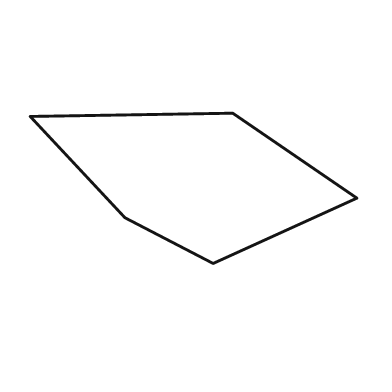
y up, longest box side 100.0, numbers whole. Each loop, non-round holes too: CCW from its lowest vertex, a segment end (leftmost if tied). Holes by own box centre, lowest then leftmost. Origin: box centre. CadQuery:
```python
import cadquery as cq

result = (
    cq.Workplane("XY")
    .moveTo(6.0, -23.0)
    .lineTo(50.0, -3.0)
    .lineTo(12.0, 23.0)
    .lineTo(-50.0, 22.0)
    .lineTo(-21.0, -9.0)
    .close()
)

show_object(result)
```